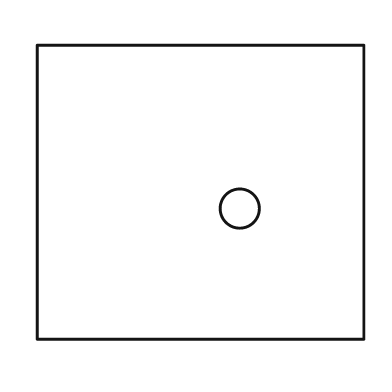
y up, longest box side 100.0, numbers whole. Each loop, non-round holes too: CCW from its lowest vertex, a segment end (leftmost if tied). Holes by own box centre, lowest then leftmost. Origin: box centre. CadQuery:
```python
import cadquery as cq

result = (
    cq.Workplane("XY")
    .moveTo(-50.0, -45.0)
    .lineTo(50.0, -45.0)
    .lineTo(50.0, 45.0)
    .lineTo(-50.0, 45.0)
    .close()
    .moveTo(12.0, -5.0)
    .circle(6.0)
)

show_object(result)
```